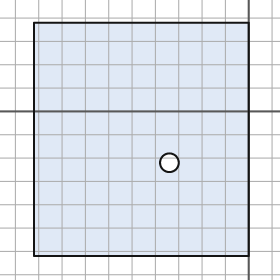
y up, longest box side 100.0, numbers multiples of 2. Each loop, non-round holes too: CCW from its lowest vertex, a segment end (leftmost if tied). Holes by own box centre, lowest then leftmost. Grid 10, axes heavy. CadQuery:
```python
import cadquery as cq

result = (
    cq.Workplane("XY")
    .moveTo(-92.0, -62.0)
    .lineTo(0.0, -62.0)
    .lineTo(0.0, 38.0)
    .lineTo(-92.0, 38.0)
    .close()
    .moveTo(-34.0, -22.0)
    .circle(4.0)
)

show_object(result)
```